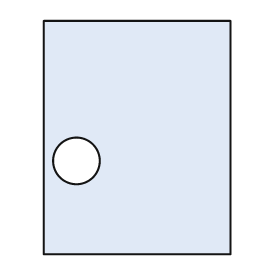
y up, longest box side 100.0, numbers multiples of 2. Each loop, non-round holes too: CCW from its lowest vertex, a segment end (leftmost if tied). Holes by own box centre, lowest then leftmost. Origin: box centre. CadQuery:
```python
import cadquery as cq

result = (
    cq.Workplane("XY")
    .moveTo(-40.0, -50.0)
    .lineTo(40.0, -50.0)
    .lineTo(40.0, 50.0)
    .lineTo(-40.0, 50.0)
    .close()
    .moveTo(-26.0, -10.0)
    .circle(10.0)
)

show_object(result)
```